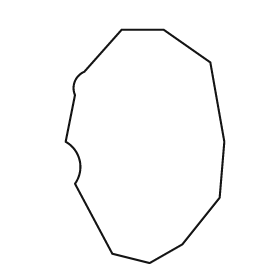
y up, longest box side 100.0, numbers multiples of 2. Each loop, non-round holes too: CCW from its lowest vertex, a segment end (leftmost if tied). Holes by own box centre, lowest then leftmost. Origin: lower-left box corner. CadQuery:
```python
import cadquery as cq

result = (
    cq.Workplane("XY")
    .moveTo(36.0, 0.0)
    .lineTo(50.0, 8.0)
    .lineTo(66.0, 28.0)
    .lineTo(68.0, 52.0)
    .lineTo(62.0, 86.0)
    .lineTo(42.0, 100.0)
    .lineTo(24.0, 100.0)
    .lineTo(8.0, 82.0)
    .threePointArc((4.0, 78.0), (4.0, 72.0))
    .lineTo(0.0, 52.0)
    .threePointArc((6.0, 44.0), (4.0, 34.0))
    .lineTo(20.0, 4.0)
    .close()
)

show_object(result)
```